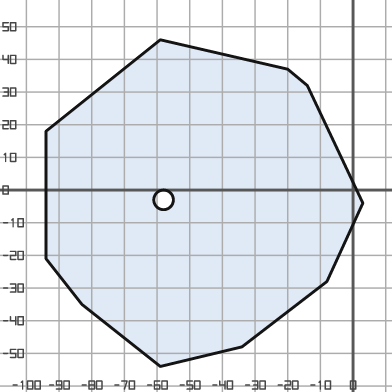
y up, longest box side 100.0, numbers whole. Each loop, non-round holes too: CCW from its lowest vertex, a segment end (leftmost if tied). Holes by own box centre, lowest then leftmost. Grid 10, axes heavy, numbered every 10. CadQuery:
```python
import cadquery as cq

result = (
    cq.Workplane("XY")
    .moveTo(-59.0, -54.0)
    .lineTo(-34.0, -48.0)
    .lineTo(-8.0, -28.0)
    .lineTo(3.0, -4.0)
    .lineTo(-14.0, 32.0)
    .lineTo(-20.0, 37.0)
    .lineTo(-59.0, 46.0)
    .lineTo(-94.0, 18.0)
    .lineTo(-94.0, -21.0)
    .lineTo(-83.0, -35.0)
    .close()
    .moveTo(-58.0, -3.0)
    .circle(3.0)
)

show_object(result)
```